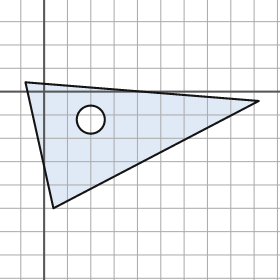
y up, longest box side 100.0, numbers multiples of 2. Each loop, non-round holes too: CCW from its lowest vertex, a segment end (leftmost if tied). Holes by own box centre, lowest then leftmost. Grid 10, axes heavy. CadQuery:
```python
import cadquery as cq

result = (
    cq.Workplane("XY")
    .moveTo(4.0, -50.0)
    .lineTo(92.0, -4.0)
    .lineTo(-8.0, 4.0)
    .close()
    .moveTo(20.0, -12.0)
    .circle(6.0)
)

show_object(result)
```